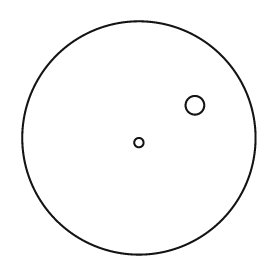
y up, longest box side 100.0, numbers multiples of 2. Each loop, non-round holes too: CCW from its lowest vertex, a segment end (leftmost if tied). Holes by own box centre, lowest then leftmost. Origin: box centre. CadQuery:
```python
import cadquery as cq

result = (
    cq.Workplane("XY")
    .moveTo(0.0, 0.0)
    .circle(50.0)
    .moveTo(0.0, -2.0)
    .circle(2.0)
    .moveTo(24.0, 14.0)
    .circle(4.0)
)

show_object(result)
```